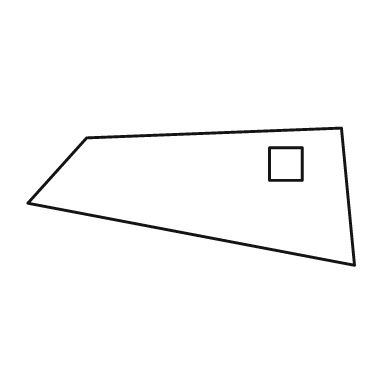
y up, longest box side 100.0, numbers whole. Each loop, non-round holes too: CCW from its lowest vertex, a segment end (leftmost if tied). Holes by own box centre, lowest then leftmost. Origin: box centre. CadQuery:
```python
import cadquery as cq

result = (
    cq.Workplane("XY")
    .moveTo(50.0, -21.0)
    .lineTo(46.0, 21.0)
    .lineTo(-32.0, 18.0)
    .lineTo(-50.0, -2.0)
    .close()
    .moveTo(24.0, 5.0)
    .lineTo(34.0, 5.0)
    .lineTo(34.0, 15.0)
    .lineTo(24.0, 15.0)
    .close()
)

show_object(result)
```